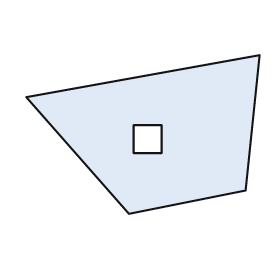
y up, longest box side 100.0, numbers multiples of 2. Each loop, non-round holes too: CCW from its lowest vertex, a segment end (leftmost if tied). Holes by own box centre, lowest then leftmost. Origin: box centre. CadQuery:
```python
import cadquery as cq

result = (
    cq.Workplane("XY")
    .moveTo(-6.0, -34.0)
    .lineTo(44.0, -24.0)
    .lineTo(50.0, 34.0)
    .lineTo(-50.0, 16.0)
    .close()
    .moveTo(-4.0, -8.0)
    .lineTo(8.0, -8.0)
    .lineTo(8.0, 4.0)
    .lineTo(-4.0, 4.0)
    .close()
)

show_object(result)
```